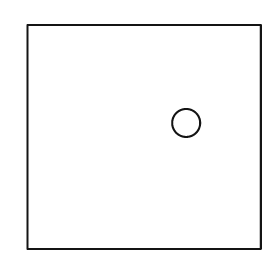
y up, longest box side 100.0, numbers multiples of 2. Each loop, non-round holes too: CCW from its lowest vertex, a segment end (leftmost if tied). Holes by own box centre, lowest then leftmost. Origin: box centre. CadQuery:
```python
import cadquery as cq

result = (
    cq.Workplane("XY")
    .moveTo(-50.0, -48.0)
    .lineTo(50.0, -48.0)
    .lineTo(50.0, 48.0)
    .lineTo(-50.0, 48.0)
    .close()
    .moveTo(18.0, 6.0)
    .circle(6.0)
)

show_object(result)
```